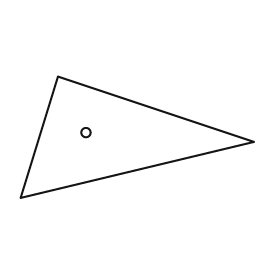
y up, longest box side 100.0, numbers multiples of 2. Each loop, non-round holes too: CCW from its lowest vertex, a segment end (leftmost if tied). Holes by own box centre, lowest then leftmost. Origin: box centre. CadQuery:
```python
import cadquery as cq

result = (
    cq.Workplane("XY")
    .moveTo(-50.0, -26.0)
    .lineTo(50.0, -2.0)
    .lineTo(-34.0, 26.0)
    .close()
    .moveTo(-22.0, 2.0)
    .circle(2.0)
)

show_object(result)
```